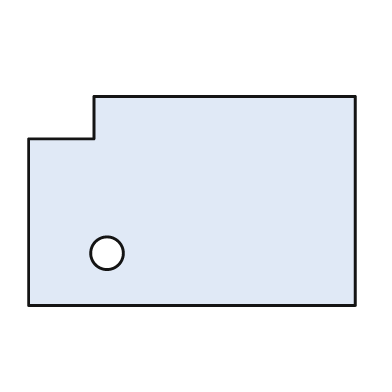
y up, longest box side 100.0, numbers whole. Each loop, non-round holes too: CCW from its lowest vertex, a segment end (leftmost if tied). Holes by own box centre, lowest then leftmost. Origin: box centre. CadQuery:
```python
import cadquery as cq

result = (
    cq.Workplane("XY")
    .moveTo(-50.0, -32.0)
    .lineTo(50.0, -32.0)
    .lineTo(50.0, 32.0)
    .lineTo(-30.0, 32.0)
    .lineTo(-30.0, 19.0)
    .lineTo(-50.0, 19.0)
    .close()
    .moveTo(-26.0, -16.0)
    .circle(5.0)
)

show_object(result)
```